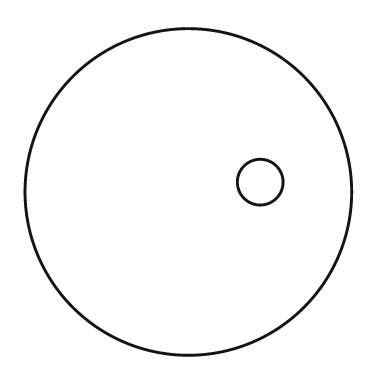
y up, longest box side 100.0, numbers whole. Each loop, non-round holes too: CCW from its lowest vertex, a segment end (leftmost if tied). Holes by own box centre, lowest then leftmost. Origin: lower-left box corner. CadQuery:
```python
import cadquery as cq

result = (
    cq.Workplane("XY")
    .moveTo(50.0, 50.0)
    .circle(50.0)
    .moveTo(72.0, 53.0)
    .circle(7.0)
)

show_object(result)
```